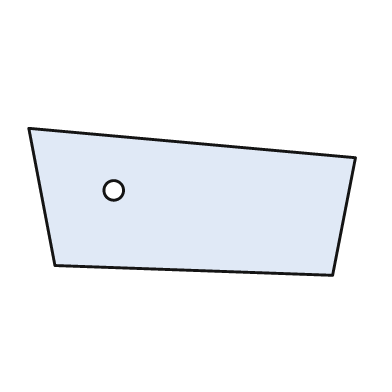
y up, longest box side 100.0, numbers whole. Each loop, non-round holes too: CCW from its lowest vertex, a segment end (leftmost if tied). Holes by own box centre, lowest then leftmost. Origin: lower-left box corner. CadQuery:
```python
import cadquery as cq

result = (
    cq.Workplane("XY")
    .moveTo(93.0, 0.0)
    .lineTo(100.0, 36.0)
    .lineTo(0.0, 45.0)
    .lineTo(8.0, 3.0)
    .close()
    .moveTo(26.0, 26.0)
    .circle(3.0)
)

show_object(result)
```